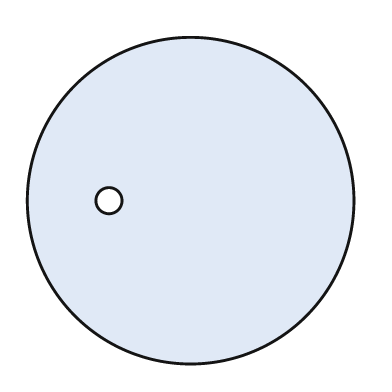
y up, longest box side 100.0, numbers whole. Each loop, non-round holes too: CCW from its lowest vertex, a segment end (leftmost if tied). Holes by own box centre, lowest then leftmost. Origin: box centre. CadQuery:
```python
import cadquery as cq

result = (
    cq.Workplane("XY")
    .moveTo(0.0, 0.0)
    .circle(50.0)
    .moveTo(-25.0, 0.0)
    .circle(4.0)
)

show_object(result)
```